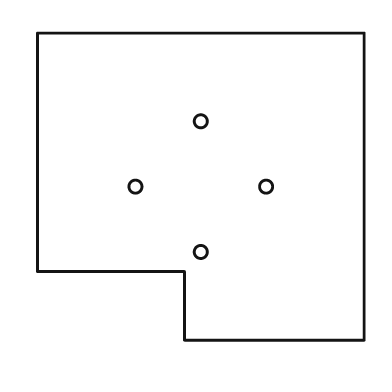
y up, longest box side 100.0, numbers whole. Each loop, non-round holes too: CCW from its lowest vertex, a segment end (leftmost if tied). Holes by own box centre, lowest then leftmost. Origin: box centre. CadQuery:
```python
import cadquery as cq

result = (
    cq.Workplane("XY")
    .moveTo(-5.0, -47.0)
    .lineTo(50.0, -47.0)
    .lineTo(50.0, 47.0)
    .lineTo(-50.0, 47.0)
    .lineTo(-50.0, -26.0)
    .lineTo(-5.0, -26.0)
    .close()
    .moveTo(0.0, -20.0)
    .circle(2.0)
    .moveTo(-20.0, 0.0)
    .circle(2.0)
    .moveTo(20.0, 0.0)
    .circle(2.0)
    .moveTo(0.0, 20.0)
    .circle(2.0)
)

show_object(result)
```